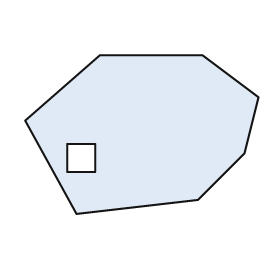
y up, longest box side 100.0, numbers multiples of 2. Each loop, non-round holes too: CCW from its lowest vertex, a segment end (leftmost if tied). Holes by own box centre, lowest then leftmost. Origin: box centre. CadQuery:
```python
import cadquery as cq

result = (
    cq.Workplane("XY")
    .moveTo(-28.0, -34.0)
    .lineTo(24.0, -28.0)
    .lineTo(44.0, -8.0)
    .lineTo(50.0, 16.0)
    .lineTo(26.0, 34.0)
    .lineTo(-18.0, 34.0)
    .lineTo(-50.0, 6.0)
    .close()
    .moveTo(-32.0, -16.0)
    .lineTo(-20.0, -16.0)
    .lineTo(-20.0, -4.0)
    .lineTo(-32.0, -4.0)
    .close()
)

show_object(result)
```